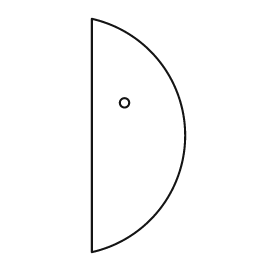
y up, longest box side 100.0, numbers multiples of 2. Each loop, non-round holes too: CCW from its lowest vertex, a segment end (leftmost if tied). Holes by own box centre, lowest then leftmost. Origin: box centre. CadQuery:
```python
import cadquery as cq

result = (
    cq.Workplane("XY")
    .moveTo(-20.0, -50.0)
    .threePointArc((20.0, 0.0), (-20.0, 50.0))
    .close()
    .moveTo(-6.0, 14.0)
    .circle(2.0)
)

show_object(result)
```